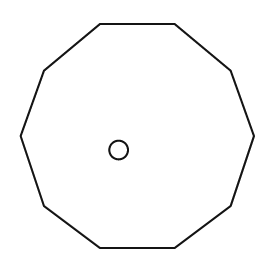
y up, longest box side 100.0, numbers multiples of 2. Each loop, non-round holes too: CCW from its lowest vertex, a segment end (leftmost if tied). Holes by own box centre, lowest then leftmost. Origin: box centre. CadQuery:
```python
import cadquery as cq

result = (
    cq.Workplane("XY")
    .moveTo(-16.0, -48.0)
    .lineTo(16.0, -48.0)
    .lineTo(40.0, -30.0)
    .lineTo(50.0, 0.0)
    .lineTo(40.0, 28.0)
    .lineTo(16.0, 48.0)
    .lineTo(-16.0, 48.0)
    .lineTo(-40.0, 28.0)
    .lineTo(-50.0, 0.0)
    .lineTo(-40.0, -30.0)
    .close()
    .moveTo(-8.0, -6.0)
    .circle(4.0)
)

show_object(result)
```